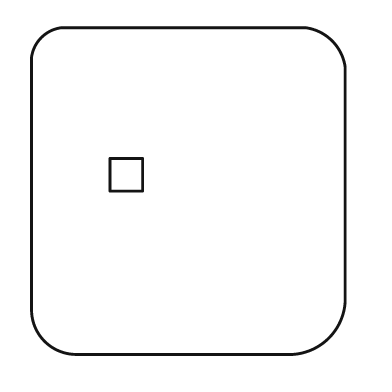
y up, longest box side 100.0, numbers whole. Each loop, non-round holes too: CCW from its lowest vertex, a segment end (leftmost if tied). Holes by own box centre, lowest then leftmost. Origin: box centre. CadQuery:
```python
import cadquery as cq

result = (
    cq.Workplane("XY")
    .moveTo(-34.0, -50.0)
    .lineTo(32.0, -50.0)
    .threePointArc((43.0, -45.0), (48.0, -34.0))
    .lineTo(48.0, 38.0)
    .threePointArc((44.0, 46.0), (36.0, 50.0))
    .lineTo(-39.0, 50.0)
    .threePointArc((-45.0, 47.0), (-48.0, 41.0))
    .lineTo(-48.0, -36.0)
    .threePointArc((-44.0, -46.0), (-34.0, -50.0))
    .close()
    .moveTo(-24.0, 0.0)
    .lineTo(-14.0, 0.0)
    .lineTo(-14.0, 10.0)
    .lineTo(-24.0, 10.0)
    .close()
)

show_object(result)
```